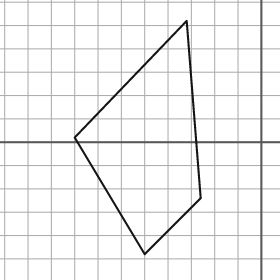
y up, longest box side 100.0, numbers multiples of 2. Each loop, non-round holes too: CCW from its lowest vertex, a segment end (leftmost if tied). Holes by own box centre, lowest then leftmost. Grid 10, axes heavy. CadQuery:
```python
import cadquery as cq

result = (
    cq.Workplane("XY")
    .moveTo(-50.0, -48.0)
    .lineTo(-26.0, -24.0)
    .lineTo(-32.0, 52.0)
    .lineTo(-80.0, 2.0)
    .close()
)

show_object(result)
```